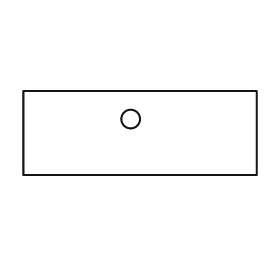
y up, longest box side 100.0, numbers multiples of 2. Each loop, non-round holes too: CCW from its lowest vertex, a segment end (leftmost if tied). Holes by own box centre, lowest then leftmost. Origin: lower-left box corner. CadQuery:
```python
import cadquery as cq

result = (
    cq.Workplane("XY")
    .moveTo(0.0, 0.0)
    .lineTo(100.0, 0.0)
    .lineTo(100.0, 36.0)
    .lineTo(0.0, 36.0)
    .close()
    .moveTo(46.0, 24.0)
    .circle(4.0)
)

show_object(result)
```